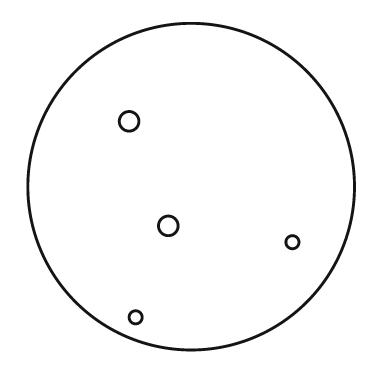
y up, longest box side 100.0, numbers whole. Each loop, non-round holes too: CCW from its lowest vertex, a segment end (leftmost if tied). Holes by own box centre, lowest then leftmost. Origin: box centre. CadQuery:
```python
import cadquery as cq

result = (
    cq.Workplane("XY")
    .moveTo(0.0, 0.0)
    .circle(50.0)
    .moveTo(-17.0, -40.0)
    .circle(2.0)
    .moveTo(31.0, -17.0)
    .circle(2.0)
    .moveTo(-7.0, -12.0)
    .circle(3.0)
    .moveTo(-19.0, 20.0)
    .circle(3.0)
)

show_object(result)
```